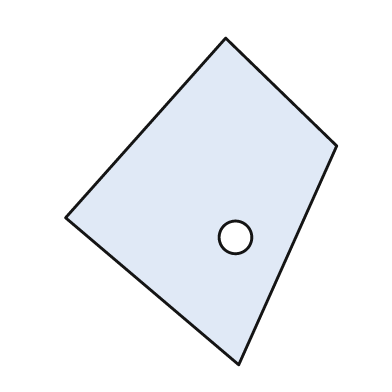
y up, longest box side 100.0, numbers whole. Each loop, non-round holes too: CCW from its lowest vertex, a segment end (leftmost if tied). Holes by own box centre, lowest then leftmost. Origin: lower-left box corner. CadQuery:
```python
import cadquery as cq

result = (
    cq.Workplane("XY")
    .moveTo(53.0, 0.0)
    .lineTo(83.0, 67.0)
    .lineTo(49.0, 100.0)
    .lineTo(0.0, 45.0)
    .close()
    .moveTo(52.0, 39.0)
    .circle(5.0)
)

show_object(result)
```